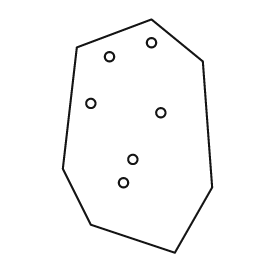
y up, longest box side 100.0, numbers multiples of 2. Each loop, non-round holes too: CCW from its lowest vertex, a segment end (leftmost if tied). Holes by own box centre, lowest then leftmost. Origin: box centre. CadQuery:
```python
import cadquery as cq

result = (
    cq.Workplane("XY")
    .moveTo(16.0, -50.0)
    .lineTo(32.0, -22.0)
    .lineTo(28.0, 32.0)
    .lineTo(6.0, 50.0)
    .lineTo(-26.0, 38.0)
    .lineTo(-32.0, -14.0)
    .lineTo(-20.0, -38.0)
    .close()
    .moveTo(-6.0, -20.0)
    .circle(2.0)
    .moveTo(-2.0, -10.0)
    .circle(2.0)
    .moveTo(10.0, 10.0)
    .circle(2.0)
    .moveTo(-20.0, 14.0)
    .circle(2.0)
    .moveTo(-12.0, 34.0)
    .circle(2.0)
    .moveTo(6.0, 40.0)
    .circle(2.0)
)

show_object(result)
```